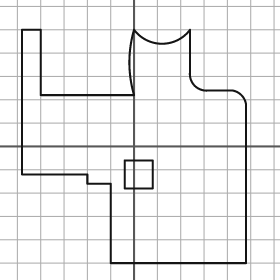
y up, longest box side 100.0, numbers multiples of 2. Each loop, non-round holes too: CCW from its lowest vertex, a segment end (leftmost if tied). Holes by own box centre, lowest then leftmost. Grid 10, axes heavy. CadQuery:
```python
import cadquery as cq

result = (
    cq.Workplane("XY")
    .moveTo(-10.0, -50.0)
    .lineTo(48.0, -50.0)
    .lineTo(48.0, 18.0)
    .threePointArc((46.0, 22.0), (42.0, 24.0))
    .lineTo(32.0, 24.0)
    .threePointArc((26.0, 26.0), (24.0, 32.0))
    .lineTo(24.0, 50.0)
    .threePointArc((12.0, 44.0), (0.0, 50.0))
    .threePointArc((-2.0, 36.0), (0.0, 22.0))
    .lineTo(-40.0, 22.0)
    .lineTo(-40.0, 50.0)
    .lineTo(-48.0, 50.0)
    .lineTo(-48.0, -12.0)
    .lineTo(-20.0, -12.0)
    .lineTo(-20.0, -16.0)
    .lineTo(-10.0, -16.0)
    .close()
    .moveTo(-4.0, -18.0)
    .lineTo(8.0, -18.0)
    .lineTo(8.0, -6.0)
    .lineTo(-4.0, -6.0)
    .close()
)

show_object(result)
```